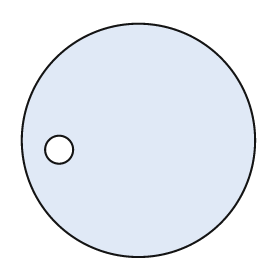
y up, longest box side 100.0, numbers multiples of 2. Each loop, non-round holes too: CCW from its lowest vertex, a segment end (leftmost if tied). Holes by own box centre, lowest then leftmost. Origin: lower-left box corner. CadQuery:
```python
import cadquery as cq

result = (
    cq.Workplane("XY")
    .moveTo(50.0, 50.0)
    .circle(50.0)
    .moveTo(16.0, 46.0)
    .circle(6.0)
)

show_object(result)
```